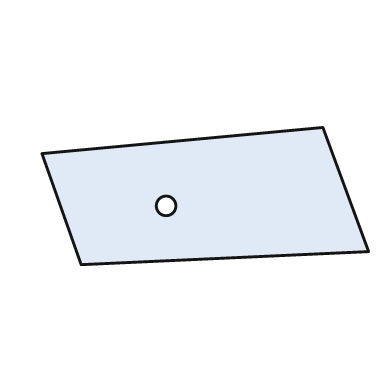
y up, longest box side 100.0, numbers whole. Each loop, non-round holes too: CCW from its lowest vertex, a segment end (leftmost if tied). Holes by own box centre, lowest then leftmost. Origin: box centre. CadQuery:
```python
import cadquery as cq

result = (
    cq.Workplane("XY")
    .moveTo(-38.0, -21.0)
    .lineTo(50.0, -17.0)
    .lineTo(36.0, 21.0)
    .lineTo(-50.0, 13.0)
    .close()
    .moveTo(-12.0, -3.0)
    .circle(3.0)
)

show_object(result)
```